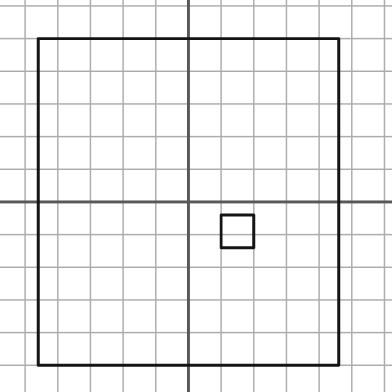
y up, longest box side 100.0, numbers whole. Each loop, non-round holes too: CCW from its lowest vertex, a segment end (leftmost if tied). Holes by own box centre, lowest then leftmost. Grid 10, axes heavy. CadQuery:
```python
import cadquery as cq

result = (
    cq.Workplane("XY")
    .moveTo(-46.0, -50.0)
    .lineTo(46.0, -50.0)
    .lineTo(46.0, 50.0)
    .lineTo(-46.0, 50.0)
    .close()
    .moveTo(10.0, -14.0)
    .lineTo(20.0, -14.0)
    .lineTo(20.0, -4.0)
    .lineTo(10.0, -4.0)
    .close()
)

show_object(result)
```